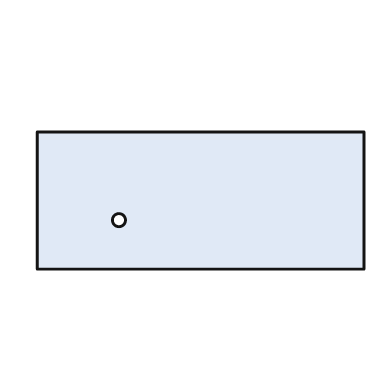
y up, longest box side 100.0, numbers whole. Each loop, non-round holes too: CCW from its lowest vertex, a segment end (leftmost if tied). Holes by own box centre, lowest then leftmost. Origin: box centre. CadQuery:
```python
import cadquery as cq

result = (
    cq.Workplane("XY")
    .moveTo(-50.0, -21.0)
    .lineTo(50.0, -21.0)
    .lineTo(50.0, 21.0)
    .lineTo(-50.0, 21.0)
    .close()
    .moveTo(-25.0, -6.0)
    .circle(2.0)
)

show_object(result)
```